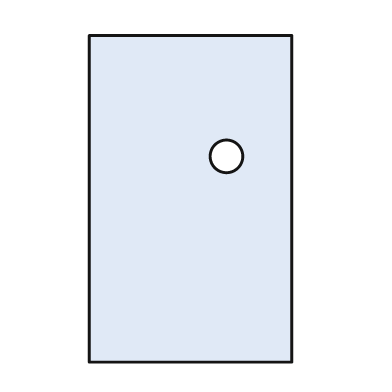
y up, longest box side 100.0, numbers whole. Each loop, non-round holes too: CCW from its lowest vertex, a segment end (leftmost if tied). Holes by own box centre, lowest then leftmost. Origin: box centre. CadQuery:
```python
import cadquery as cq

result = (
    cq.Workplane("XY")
    .moveTo(-31.0, -50.0)
    .lineTo(31.0, -50.0)
    .lineTo(31.0, 50.0)
    .lineTo(-31.0, 50.0)
    .close()
    .moveTo(11.0, 13.0)
    .circle(5.0)
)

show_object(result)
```